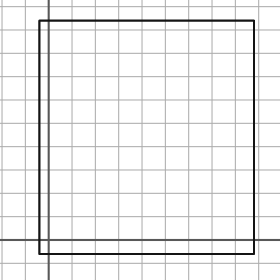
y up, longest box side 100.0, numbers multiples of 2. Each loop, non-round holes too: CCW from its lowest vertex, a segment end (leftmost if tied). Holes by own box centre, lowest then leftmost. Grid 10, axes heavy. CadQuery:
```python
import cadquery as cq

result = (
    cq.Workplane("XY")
    .moveTo(-4.0, -6.0)
    .lineTo(88.0, -6.0)
    .lineTo(88.0, 94.0)
    .lineTo(-4.0, 94.0)
    .close()
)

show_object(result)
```